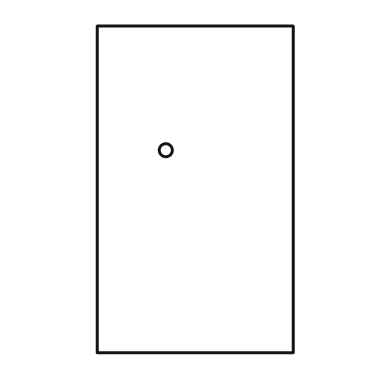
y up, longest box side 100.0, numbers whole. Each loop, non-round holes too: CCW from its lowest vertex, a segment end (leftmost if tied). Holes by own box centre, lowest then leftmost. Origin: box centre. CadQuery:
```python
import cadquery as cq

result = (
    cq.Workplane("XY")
    .moveTo(-30.0, -50.0)
    .lineTo(30.0, -50.0)
    .lineTo(30.0, 50.0)
    .lineTo(-30.0, 50.0)
    .close()
    .moveTo(-9.0, 12.0)
    .circle(2.0)
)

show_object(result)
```